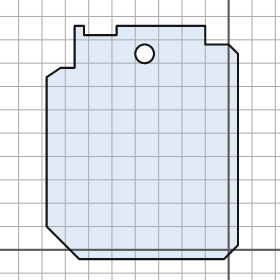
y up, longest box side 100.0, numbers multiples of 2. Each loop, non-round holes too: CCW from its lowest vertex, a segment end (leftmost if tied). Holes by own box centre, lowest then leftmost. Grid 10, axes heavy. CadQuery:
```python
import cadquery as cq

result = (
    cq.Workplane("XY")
    .moveTo(-64.0, -4.0)
    .lineTo(-2.0, -4.0)
    .lineTo(4.0, 2.0)
    .lineTo(4.0, 84.0)
    .lineTo(0.0, 88.0)
    .lineTo(-10.0, 88.0)
    .lineTo(-10.0, 96.0)
    .lineTo(-48.0, 96.0)
    .lineTo(-48.0, 92.0)
    .lineTo(-62.0, 92.0)
    .lineTo(-62.0, 96.0)
    .lineTo(-66.0, 96.0)
    .lineTo(-66.0, 78.0)
    .lineTo(-72.0, 78.0)
    .lineTo(-78.0, 74.0)
    .lineTo(-78.0, 10.0)
    .close()
    .moveTo(-36.0, 84.0)
    .circle(4.0)
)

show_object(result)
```